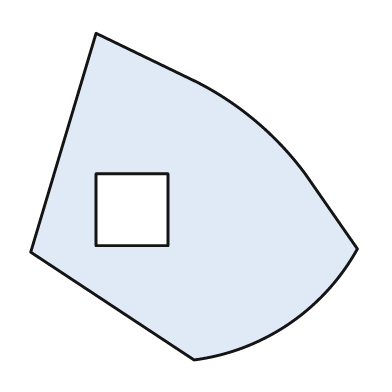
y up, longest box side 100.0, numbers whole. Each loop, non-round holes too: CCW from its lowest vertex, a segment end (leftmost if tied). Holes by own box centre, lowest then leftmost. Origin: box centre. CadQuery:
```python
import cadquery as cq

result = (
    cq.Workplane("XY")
    .moveTo(0.0, -50.0)
    .threePointArc((29.0, -39.0), (50.0, -16.0))
    .lineTo(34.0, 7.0)
    .threePointArc((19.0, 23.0), (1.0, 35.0))
    .lineTo(-30.0, 50.0)
    .lineTo(-50.0, -17.0)
    .close()
    .moveTo(-30.0, -15.0)
    .lineTo(-8.0, -15.0)
    .lineTo(-8.0, 7.0)
    .lineTo(-30.0, 7.0)
    .close()
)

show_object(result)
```